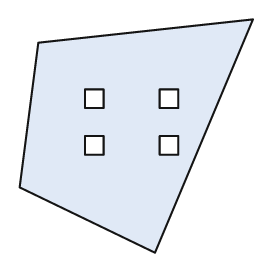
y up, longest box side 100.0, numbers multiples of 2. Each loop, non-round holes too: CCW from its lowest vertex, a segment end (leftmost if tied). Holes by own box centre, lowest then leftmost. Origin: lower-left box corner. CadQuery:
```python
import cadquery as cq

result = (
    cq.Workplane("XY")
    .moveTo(58.0, 0.0)
    .lineTo(100.0, 100.0)
    .lineTo(8.0, 90.0)
    .lineTo(0.0, 28.0)
    .close()
    .moveTo(28.0, 42.0)
    .lineTo(36.0, 42.0)
    .lineTo(36.0, 50.0)
    .lineTo(28.0, 50.0)
    .close()
    .moveTo(60.0, 42.0)
    .lineTo(68.0, 42.0)
    .lineTo(68.0, 50.0)
    .lineTo(60.0, 50.0)
    .close()
    .moveTo(28.0, 62.0)
    .lineTo(36.0, 62.0)
    .lineTo(36.0, 70.0)
    .lineTo(28.0, 70.0)
    .close()
    .moveTo(60.0, 62.0)
    .lineTo(68.0, 62.0)
    .lineTo(68.0, 70.0)
    .lineTo(60.0, 70.0)
    .close()
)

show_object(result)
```